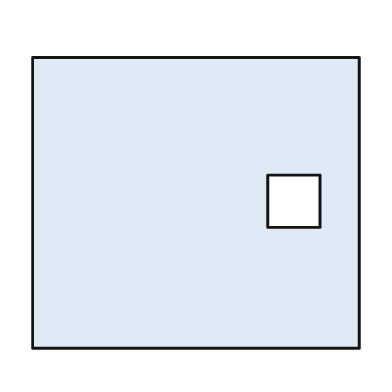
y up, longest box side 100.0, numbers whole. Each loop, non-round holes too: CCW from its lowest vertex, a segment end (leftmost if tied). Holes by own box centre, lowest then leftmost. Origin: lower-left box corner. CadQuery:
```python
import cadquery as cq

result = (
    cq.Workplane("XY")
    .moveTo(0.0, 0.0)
    .lineTo(100.0, 0.0)
    .lineTo(100.0, 89.0)
    .lineTo(0.0, 89.0)
    .close()
    .moveTo(72.0, 37.0)
    .lineTo(88.0, 37.0)
    .lineTo(88.0, 53.0)
    .lineTo(72.0, 53.0)
    .close()
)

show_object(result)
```